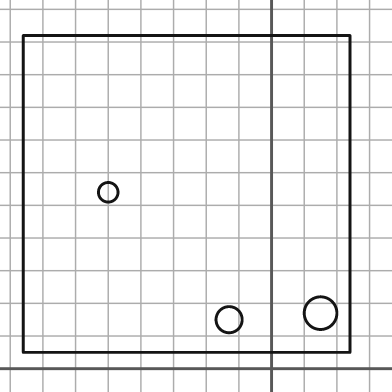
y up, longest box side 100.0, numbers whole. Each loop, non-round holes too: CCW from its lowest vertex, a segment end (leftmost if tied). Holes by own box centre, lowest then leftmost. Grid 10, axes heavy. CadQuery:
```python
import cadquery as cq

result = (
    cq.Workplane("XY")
    .moveTo(-76.0, 5.0)
    .lineTo(24.0, 5.0)
    .lineTo(24.0, 102.0)
    .lineTo(-76.0, 102.0)
    .close()
    .moveTo(-13.0, 15.0)
    .circle(4.0)
    .moveTo(15.0, 17.0)
    .circle(5.0)
    .moveTo(-50.0, 54.0)
    .circle(3.0)
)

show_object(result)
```